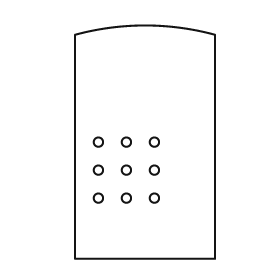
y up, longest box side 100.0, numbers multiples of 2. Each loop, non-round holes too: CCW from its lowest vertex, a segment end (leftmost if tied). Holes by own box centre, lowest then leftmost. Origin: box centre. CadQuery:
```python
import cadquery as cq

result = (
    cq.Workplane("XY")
    .moveTo(-30.0, -50.0)
    .lineTo(30.0, -50.0)
    .lineTo(30.0, 46.0)
    .threePointArc((0.0, 50.0), (-30.0, 46.0))
    .close()
    .moveTo(-20.0, -24.0)
    .circle(2.0)
    .moveTo(-8.0, -24.0)
    .circle(2.0)
    .moveTo(4.0, -24.0)
    .circle(2.0)
    .moveTo(-20.0, -12.0)
    .circle(2.0)
    .moveTo(-8.0, -12.0)
    .circle(2.0)
    .moveTo(4.0, -12.0)
    .circle(2.0)
    .moveTo(-20.0, 0.0)
    .circle(2.0)
    .moveTo(-8.0, 0.0)
    .circle(2.0)
    .moveTo(4.0, 0.0)
    .circle(2.0)
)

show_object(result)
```